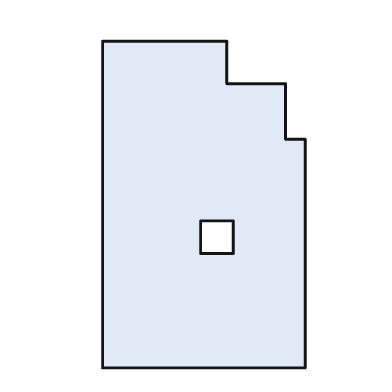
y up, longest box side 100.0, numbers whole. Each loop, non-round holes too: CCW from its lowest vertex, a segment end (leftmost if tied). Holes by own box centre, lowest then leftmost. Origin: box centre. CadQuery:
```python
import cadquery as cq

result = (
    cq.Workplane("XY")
    .moveTo(-31.0, -50.0)
    .lineTo(31.0, -50.0)
    .lineTo(31.0, 20.0)
    .lineTo(25.0, 20.0)
    .lineTo(25.0, 37.0)
    .lineTo(7.0, 37.0)
    .lineTo(7.0, 50.0)
    .lineTo(-31.0, 50.0)
    .close()
    .moveTo(-1.0, -15.0)
    .lineTo(9.0, -15.0)
    .lineTo(9.0, -5.0)
    .lineTo(-1.0, -5.0)
    .close()
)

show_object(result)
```